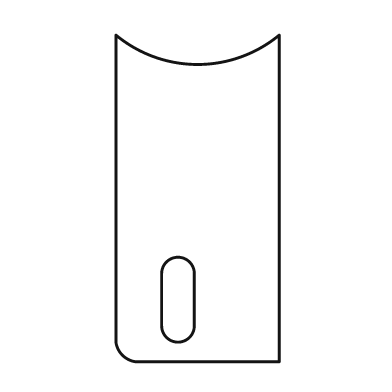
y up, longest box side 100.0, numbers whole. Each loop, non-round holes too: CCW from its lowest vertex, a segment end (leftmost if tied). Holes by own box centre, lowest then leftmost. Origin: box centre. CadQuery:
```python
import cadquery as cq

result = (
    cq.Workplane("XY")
    .moveTo(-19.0, -50.0)
    .lineTo(25.0, -50.0)
    .lineTo(25.0, 50.0)
    .threePointArc((0.0, 41.0), (-25.0, 50.0))
    .lineTo(-25.0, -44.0)
    .threePointArc((-23.0, -48.0), (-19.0, -50.0))
    .close()
    .moveTo(-11.0, -39.0)
    .threePointArc((-6.0, -44.0), (-1.0, -39.0))
    .lineTo(-1.0, -23.0)
    .threePointArc((-6.0, -18.0), (-11.0, -23.0))
    .close()
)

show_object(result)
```